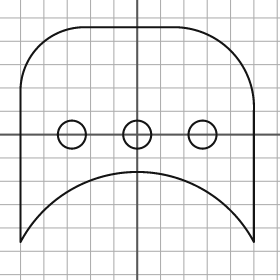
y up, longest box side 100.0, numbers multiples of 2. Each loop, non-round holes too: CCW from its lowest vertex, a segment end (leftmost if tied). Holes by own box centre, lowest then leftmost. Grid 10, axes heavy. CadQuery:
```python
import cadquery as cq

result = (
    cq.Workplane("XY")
    .moveTo(-50.0, -46.0)
    .threePointArc((0.0, -16.0), (50.0, -46.0))
    .lineTo(50.0, 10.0)
    .threePointArc((40.0, 36.0), (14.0, 46.0))
    .lineTo(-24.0, 46.0)
    .threePointArc((-42.0, 38.0), (-50.0, 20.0))
    .close()
    .moveTo(-28.0, 0.0)
    .circle(6.0)
    .moveTo(0.0, 0.0)
    .circle(6.0)
    .moveTo(28.0, 0.0)
    .circle(6.0)
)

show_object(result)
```